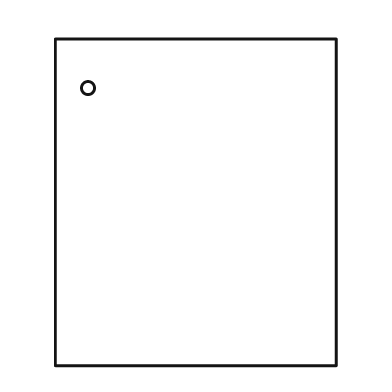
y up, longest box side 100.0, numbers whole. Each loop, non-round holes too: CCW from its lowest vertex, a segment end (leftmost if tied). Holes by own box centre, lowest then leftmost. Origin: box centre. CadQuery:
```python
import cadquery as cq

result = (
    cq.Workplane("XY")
    .moveTo(-43.0, -50.0)
    .lineTo(43.0, -50.0)
    .lineTo(43.0, 50.0)
    .lineTo(-43.0, 50.0)
    .close()
    .moveTo(-33.0, 35.0)
    .circle(2.0)
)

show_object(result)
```